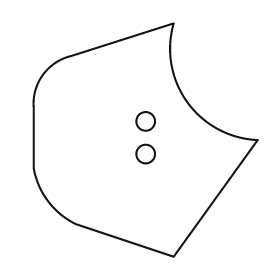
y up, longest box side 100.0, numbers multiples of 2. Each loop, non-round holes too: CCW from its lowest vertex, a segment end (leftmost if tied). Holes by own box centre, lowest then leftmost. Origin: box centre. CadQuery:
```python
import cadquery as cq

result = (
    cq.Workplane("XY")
    .moveTo(12.0, -50.0)
    .lineTo(48.0, 0.0)
    .threePointArc((18.0, 16.0), (12.0, 50.0))
    .lineTo(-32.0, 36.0)
    .threePointArc((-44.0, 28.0), (-48.0, 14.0))
    .lineTo(-48.0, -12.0)
    .threePointArc((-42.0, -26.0), (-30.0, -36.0))
    .close()
    .moveTo(0.0, -6.0)
    .circle(4.0)
    .moveTo(0.0, 8.0)
    .circle(4.0)
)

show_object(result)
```